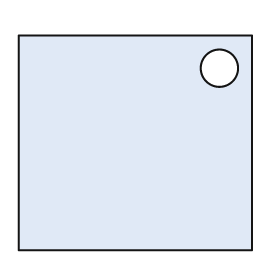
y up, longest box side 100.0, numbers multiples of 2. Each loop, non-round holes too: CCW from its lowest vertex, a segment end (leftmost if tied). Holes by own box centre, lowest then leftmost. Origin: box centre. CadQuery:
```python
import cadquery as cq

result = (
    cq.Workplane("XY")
    .moveTo(-50.0, -46.0)
    .lineTo(50.0, -46.0)
    .lineTo(50.0, 46.0)
    .lineTo(-50.0, 46.0)
    .close()
    .moveTo(36.0, 32.0)
    .circle(8.0)
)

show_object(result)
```